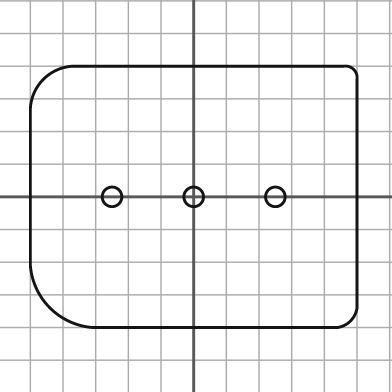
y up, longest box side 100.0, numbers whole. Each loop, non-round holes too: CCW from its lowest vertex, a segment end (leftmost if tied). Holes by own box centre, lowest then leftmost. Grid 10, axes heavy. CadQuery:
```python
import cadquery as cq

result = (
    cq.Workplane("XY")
    .moveTo(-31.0, -40.0)
    .lineTo(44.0, -40.0)
    .threePointArc((48.0, -38.0), (50.0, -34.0))
    .lineTo(50.0, 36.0)
    .threePointArc((49.0, 39.0), (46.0, 40.0))
    .lineTo(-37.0, 40.0)
    .threePointArc((-46.0, 36.0), (-50.0, 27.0))
    .lineTo(-50.0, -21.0)
    .threePointArc((-44.0, -34.0), (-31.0, -40.0))
    .close()
    .moveTo(-25.0, 0.0)
    .circle(3.0)
    .moveTo(0.0, 0.0)
    .circle(3.0)
    .moveTo(25.0, 0.0)
    .circle(3.0)
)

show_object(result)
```